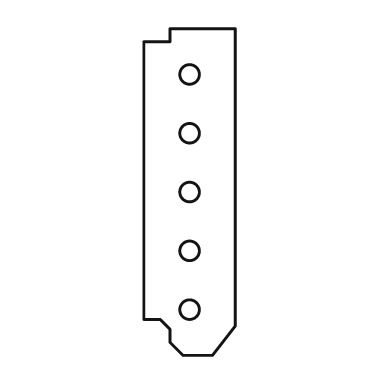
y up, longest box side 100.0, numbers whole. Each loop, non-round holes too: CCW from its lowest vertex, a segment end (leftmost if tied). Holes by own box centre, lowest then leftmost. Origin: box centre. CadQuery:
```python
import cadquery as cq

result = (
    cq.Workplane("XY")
    .moveTo(-2.0, -50.0)
    .lineTo(7.0, -50.0)
    .lineTo(14.0, -41.0)
    .lineTo(14.0, 50.0)
    .lineTo(-6.0, 50.0)
    .lineTo(-6.0, 46.0)
    .lineTo(-14.0, 46.0)
    .lineTo(-14.0, -39.0)
    .lineTo(-9.0, -39.0)
    .lineTo(-6.0, -42.0)
    .lineTo(-6.0, -46.0)
    .close()
    .moveTo(0.0, -36.0)
    .circle(3.0)
    .moveTo(0.0, -18.0)
    .circle(3.0)
    .moveTo(0.0, 0.0)
    .circle(3.0)
    .moveTo(0.0, 18.0)
    .circle(3.0)
    .moveTo(0.0, 36.0)
    .circle(3.0)
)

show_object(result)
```